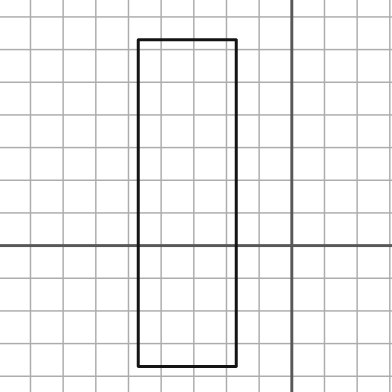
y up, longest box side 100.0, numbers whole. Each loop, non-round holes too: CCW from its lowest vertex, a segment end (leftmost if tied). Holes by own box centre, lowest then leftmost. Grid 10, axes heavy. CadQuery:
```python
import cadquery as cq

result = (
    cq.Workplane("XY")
    .moveTo(-47.0, -37.0)
    .lineTo(-17.0, -37.0)
    .lineTo(-17.0, 63.0)
    .lineTo(-47.0, 63.0)
    .close()
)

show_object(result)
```